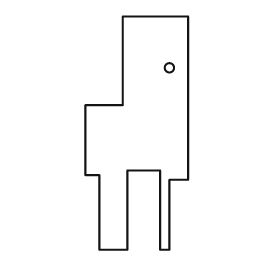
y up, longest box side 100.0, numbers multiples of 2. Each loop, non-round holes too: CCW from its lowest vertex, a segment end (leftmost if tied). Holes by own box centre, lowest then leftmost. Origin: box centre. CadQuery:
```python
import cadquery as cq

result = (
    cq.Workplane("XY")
    .moveTo(-16.0, -50.0)
    .lineTo(-4.0, -50.0)
    .lineTo(-4.0, -16.0)
    .lineTo(10.0, -16.0)
    .lineTo(10.0, -50.0)
    .lineTo(14.0, -50.0)
    .lineTo(14.0, -20.0)
    .lineTo(22.0, -20.0)
    .lineTo(22.0, 50.0)
    .lineTo(-6.0, 50.0)
    .lineTo(-6.0, 12.0)
    .lineTo(-22.0, 12.0)
    .lineTo(-22.0, -18.0)
    .lineTo(-16.0, -18.0)
    .close()
    .moveTo(14.0, 28.0)
    .circle(2.0)
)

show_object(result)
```